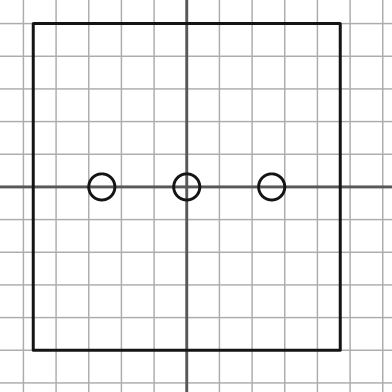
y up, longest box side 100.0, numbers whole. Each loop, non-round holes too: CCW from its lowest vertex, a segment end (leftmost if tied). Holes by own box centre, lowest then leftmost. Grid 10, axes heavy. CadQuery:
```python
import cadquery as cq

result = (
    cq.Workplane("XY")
    .moveTo(-47.0, -50.0)
    .lineTo(47.0, -50.0)
    .lineTo(47.0, 50.0)
    .lineTo(-47.0, 50.0)
    .close()
    .moveTo(-26.0, 0.0)
    .circle(4.0)
    .moveTo(0.0, 0.0)
    .circle(4.0)
    .moveTo(26.0, 0.0)
    .circle(4.0)
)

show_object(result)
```